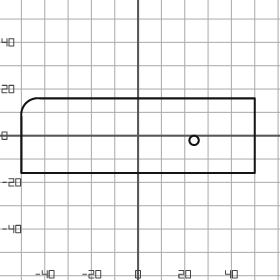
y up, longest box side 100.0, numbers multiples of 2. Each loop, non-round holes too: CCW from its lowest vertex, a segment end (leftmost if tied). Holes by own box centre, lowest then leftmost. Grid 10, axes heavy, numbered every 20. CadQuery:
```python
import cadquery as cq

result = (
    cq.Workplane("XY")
    .moveTo(-50.0, -16.0)
    .lineTo(50.0, -16.0)
    .lineTo(50.0, 16.0)
    .lineTo(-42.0, 16.0)
    .threePointArc((-48.0, 14.0), (-50.0, 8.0))
    .close()
    .moveTo(24.0, -2.0)
    .circle(2.0)
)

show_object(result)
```